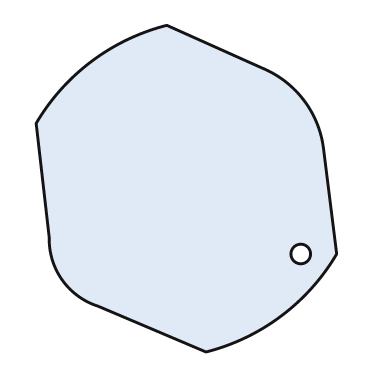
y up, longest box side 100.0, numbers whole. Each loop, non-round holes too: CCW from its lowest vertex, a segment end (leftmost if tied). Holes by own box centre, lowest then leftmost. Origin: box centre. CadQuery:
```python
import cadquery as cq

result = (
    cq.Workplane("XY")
    .moveTo(6.0, -50.0)
    .threePointArc((29.0, -39.0), (46.0, -20.0))
    .lineTo(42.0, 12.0)
    .threePointArc((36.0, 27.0), (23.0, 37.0))
    .lineTo(-6.0, 50.0)
    .threePointArc((-29.0, 39.0), (-46.0, 20.0))
    .lineTo(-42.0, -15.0)
    .threePointArc((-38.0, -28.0), (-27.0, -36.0))
    .close()
    .moveTo(35.0, -20.0)
    .circle(3.0)
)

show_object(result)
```